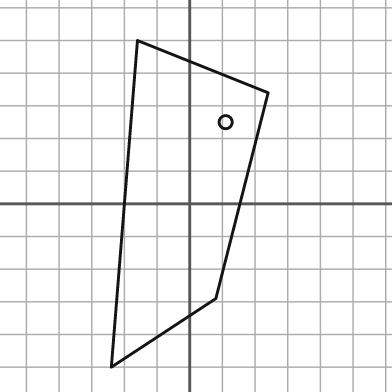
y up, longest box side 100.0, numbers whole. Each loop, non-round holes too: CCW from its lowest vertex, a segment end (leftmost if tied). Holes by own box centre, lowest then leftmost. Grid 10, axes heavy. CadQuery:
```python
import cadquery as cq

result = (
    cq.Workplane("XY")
    .moveTo(-24.0, -50.0)
    .lineTo(8.0, -29.0)
    .lineTo(24.0, 34.0)
    .lineTo(-16.0, 50.0)
    .close()
    .moveTo(11.0, 25.0)
    .circle(2.0)
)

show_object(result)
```